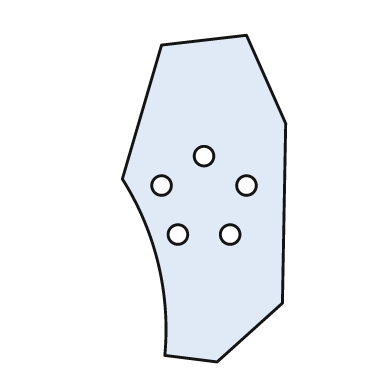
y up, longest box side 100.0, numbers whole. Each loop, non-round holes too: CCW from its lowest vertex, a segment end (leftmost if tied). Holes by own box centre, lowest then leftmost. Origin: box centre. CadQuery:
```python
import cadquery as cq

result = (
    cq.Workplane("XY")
    .moveTo(4.0, -50.0)
    .lineTo(24.0, -32.0)
    .lineTo(25.0, 23.0)
    .lineTo(13.0, 50.0)
    .lineTo(-13.0, 47.0)
    .lineTo(-25.0, 6.0)
    .threePointArc((-14.0, -20.0), (-12.0, -48.0))
    .close()
    .moveTo(-8.0, -11.0)
    .circle(3.0)
    .moveTo(8.0, -11.0)
    .circle(3.0)
    .moveTo(-13.0, 4.0)
    .circle(3.0)
    .moveTo(13.0, 4.0)
    .circle(3.0)
    .moveTo(0.0, 13.0)
    .circle(3.0)
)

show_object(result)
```